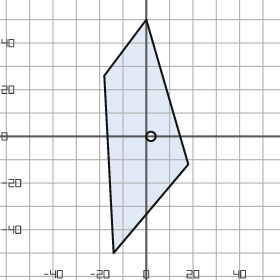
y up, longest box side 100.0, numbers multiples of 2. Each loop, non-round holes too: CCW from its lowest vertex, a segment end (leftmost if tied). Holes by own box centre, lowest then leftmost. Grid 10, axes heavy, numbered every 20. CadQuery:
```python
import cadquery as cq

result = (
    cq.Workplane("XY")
    .moveTo(-14.0, -50.0)
    .lineTo(18.0, -12.0)
    .lineTo(0.0, 50.0)
    .lineTo(-18.0, 26.0)
    .close()
    .moveTo(2.0, 0.0)
    .circle(2.0)
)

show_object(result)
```